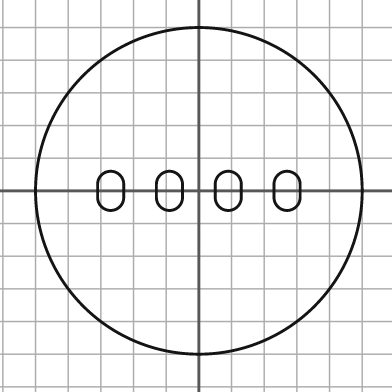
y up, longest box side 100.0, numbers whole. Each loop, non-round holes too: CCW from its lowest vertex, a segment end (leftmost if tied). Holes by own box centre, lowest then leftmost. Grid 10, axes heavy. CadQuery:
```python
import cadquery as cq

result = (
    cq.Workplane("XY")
    .moveTo(0.0, 0.0)
    .circle(50.0)
    .moveTo(-31.0, -2.0)
    .threePointArc((-27.0, -6.0), (-23.0, -2.0))
    .lineTo(-23.0, 2.0)
    .threePointArc((-27.0, 6.0), (-31.0, 2.0))
    .close()
    .moveTo(-13.0, -2.0)
    .threePointArc((-9.0, -6.0), (-5.0, -2.0))
    .lineTo(-5.0, 2.0)
    .threePointArc((-9.0, 6.0), (-13.0, 2.0))
    .close()
    .moveTo(5.0, -2.0)
    .threePointArc((9.0, -6.0), (13.0, -2.0))
    .lineTo(13.0, 2.0)
    .threePointArc((9.0, 6.0), (5.0, 2.0))
    .close()
    .moveTo(23.0, -2.0)
    .threePointArc((27.0, -6.0), (31.0, -2.0))
    .lineTo(31.0, 2.0)
    .threePointArc((27.0, 6.0), (23.0, 2.0))
    .close()
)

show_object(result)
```